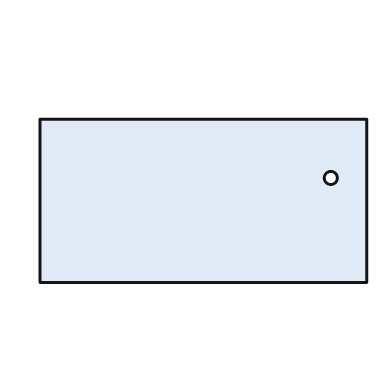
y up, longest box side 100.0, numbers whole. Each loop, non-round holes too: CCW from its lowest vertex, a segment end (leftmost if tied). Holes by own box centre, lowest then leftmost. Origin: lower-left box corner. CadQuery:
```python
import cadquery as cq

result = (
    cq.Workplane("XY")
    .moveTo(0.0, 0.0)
    .lineTo(100.0, 0.0)
    .lineTo(100.0, 50.0)
    .lineTo(0.0, 50.0)
    .close()
    .moveTo(89.0, 32.0)
    .circle(2.0)
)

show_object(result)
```